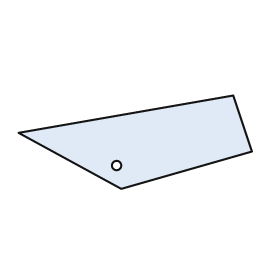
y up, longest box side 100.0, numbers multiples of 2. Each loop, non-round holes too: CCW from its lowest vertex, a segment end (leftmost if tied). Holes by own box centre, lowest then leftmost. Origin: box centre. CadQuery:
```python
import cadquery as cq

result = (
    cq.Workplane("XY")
    .moveTo(-6.0, -20.0)
    .lineTo(50.0, -4.0)
    .lineTo(42.0, 20.0)
    .lineTo(-50.0, 4.0)
    .close()
    .moveTo(-8.0, -10.0)
    .circle(2.0)
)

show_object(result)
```